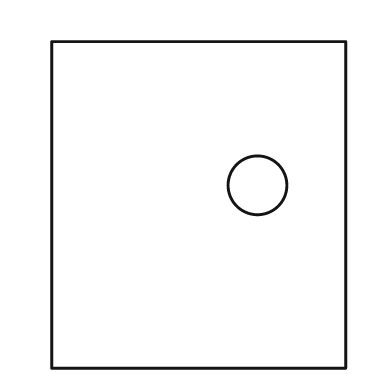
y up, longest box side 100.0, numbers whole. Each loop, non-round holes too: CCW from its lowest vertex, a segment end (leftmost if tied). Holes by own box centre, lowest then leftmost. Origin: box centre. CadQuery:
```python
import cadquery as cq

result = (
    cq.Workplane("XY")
    .moveTo(-45.0, -50.0)
    .lineTo(45.0, -50.0)
    .lineTo(45.0, 50.0)
    .lineTo(-45.0, 50.0)
    .close()
    .moveTo(18.0, 6.0)
    .circle(9.0)
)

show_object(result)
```